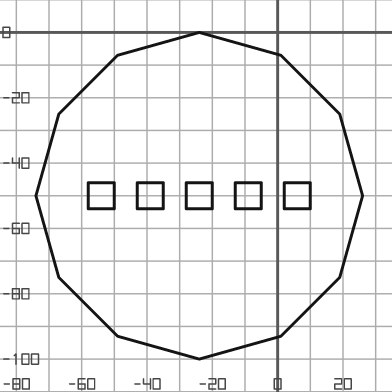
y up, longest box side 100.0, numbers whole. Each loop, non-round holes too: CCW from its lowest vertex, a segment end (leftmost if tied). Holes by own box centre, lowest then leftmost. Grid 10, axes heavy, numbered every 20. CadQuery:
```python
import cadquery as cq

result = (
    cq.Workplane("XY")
    .moveTo(-24.0, -100.0)
    .lineTo(1.0, -93.0)
    .lineTo(19.0, -75.0)
    .lineTo(26.0, -50.0)
    .lineTo(19.0, -25.0)
    .lineTo(1.0, -7.0)
    .lineTo(-24.0, 0.0)
    .lineTo(-49.0, -7.0)
    .lineTo(-67.0, -25.0)
    .lineTo(-74.0, -50.0)
    .lineTo(-67.0, -75.0)
    .lineTo(-49.0, -93.0)
    .close()
    .moveTo(-58.0, -54.0)
    .lineTo(-50.0, -54.0)
    .lineTo(-50.0, -46.0)
    .lineTo(-58.0, -46.0)
    .close()
    .moveTo(-43.0, -54.0)
    .lineTo(-35.0, -54.0)
    .lineTo(-35.0, -46.0)
    .lineTo(-43.0, -46.0)
    .close()
    .moveTo(-28.0, -54.0)
    .lineTo(-20.0, -54.0)
    .lineTo(-20.0, -46.0)
    .lineTo(-28.0, -46.0)
    .close()
    .moveTo(-13.0, -54.0)
    .lineTo(-5.0, -54.0)
    .lineTo(-5.0, -46.0)
    .lineTo(-13.0, -46.0)
    .close()
    .moveTo(2.0, -54.0)
    .lineTo(10.0, -54.0)
    .lineTo(10.0, -46.0)
    .lineTo(2.0, -46.0)
    .close()
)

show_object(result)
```